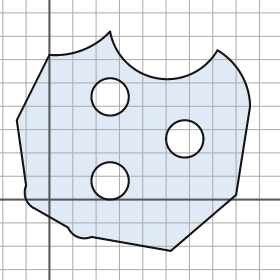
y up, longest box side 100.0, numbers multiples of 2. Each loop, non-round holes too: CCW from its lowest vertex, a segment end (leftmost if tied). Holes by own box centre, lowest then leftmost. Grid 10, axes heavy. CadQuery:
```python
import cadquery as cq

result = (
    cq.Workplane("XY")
    .moveTo(52.0, -22.0)
    .lineTo(80.0, 2.0)
    .lineTo(86.0, 40.0)
    .threePointArc((82.0, 54.0), (72.0, 64.0))
    .threePointArc((46.0, 52.0), (26.0, 72.0))
    .threePointArc((14.0, 64.0), (0.0, 62.0))
    .lineTo(-14.0, 34.0)
    .lineTo(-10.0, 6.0)
    .threePointArc((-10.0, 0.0), (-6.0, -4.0))
    .lineTo(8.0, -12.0)
    .threePointArc((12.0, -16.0), (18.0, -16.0))
    .close()
    .moveTo(26.0, 8.0)
    .circle(8.0)
    .moveTo(58.0, 26.0)
    .circle(8.0)
    .moveTo(26.0, 44.0)
    .circle(8.0)
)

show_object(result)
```